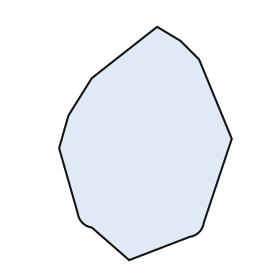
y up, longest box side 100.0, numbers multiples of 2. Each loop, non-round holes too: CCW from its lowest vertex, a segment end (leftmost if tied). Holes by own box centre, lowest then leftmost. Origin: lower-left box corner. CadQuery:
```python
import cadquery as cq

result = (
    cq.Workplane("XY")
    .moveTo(30.0, 0.0)
    .lineTo(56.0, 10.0)
    .threePointArc((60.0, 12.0), (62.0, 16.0))
    .lineTo(74.0, 52.0)
    .lineTo(60.0, 86.0)
    .lineTo(52.0, 94.0)
    .lineTo(42.0, 100.0)
    .lineTo(14.0, 78.0)
    .lineTo(4.0, 62.0)
    .lineTo(0.0, 48.0)
    .lineTo(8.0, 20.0)
    .threePointArc((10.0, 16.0), (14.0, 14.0))
    .close()
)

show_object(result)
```